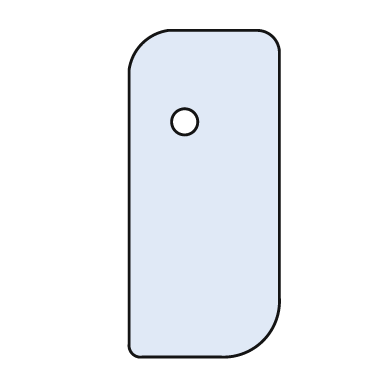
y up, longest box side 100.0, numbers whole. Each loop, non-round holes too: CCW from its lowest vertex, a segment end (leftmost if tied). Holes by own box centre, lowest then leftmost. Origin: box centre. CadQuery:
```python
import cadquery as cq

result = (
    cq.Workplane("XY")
    .moveTo(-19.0, -50.0)
    .lineTo(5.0, -50.0)
    .threePointArc((18.0, -45.0), (23.0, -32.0))
    .lineTo(23.0, 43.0)
    .threePointArc((21.0, 48.0), (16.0, 50.0))
    .lineTo(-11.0, 50.0)
    .threePointArc((-19.0, 46.0), (-23.0, 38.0))
    .lineTo(-23.0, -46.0)
    .threePointArc((-22.0, -49.0), (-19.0, -50.0))
    .close()
    .moveTo(-6.0, 22.0)
    .circle(4.0)
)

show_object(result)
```